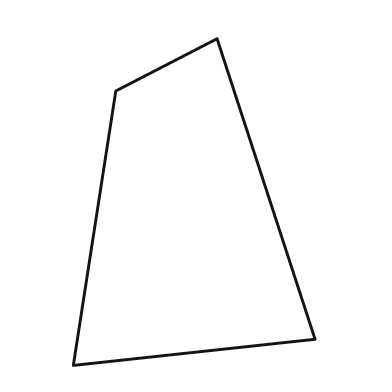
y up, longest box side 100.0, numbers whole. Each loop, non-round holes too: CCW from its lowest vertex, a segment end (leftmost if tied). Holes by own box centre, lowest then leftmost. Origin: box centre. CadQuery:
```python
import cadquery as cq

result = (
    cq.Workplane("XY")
    .moveTo(-37.0, -50.0)
    .lineTo(37.0, -42.0)
    .lineTo(7.0, 50.0)
    .lineTo(-24.0, 34.0)
    .close()
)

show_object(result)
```